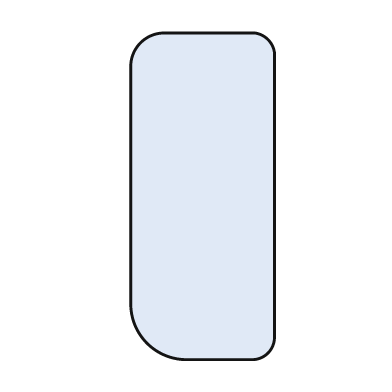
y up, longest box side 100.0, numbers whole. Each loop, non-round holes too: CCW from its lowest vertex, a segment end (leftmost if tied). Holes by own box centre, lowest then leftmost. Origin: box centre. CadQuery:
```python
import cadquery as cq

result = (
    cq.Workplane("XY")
    .moveTo(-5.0, -50.0)
    .lineTo(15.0, -50.0)
    .threePointArc((20.0, -48.0), (22.0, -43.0))
    .lineTo(22.0, 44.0)
    .threePointArc((20.0, 48.0), (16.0, 50.0))
    .lineTo(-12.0, 50.0)
    .threePointArc((-19.0, 47.0), (-22.0, 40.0))
    .lineTo(-22.0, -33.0)
    .threePointArc((-17.0, -45.0), (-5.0, -50.0))
    .close()
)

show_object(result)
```